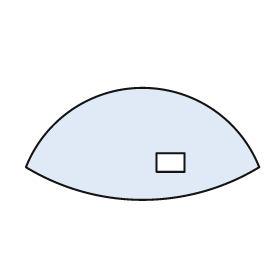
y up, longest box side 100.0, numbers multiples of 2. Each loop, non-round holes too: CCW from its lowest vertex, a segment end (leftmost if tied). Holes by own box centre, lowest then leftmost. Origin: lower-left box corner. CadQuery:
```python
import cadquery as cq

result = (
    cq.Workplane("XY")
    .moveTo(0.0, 14.0)
    .threePointArc((50.0, 0.0), (100.0, 14.0))
    .threePointArc((50.0, 48.0), (0.0, 14.0))
    .close()
    .moveTo(56.0, 12.0)
    .lineTo(68.0, 12.0)
    .lineTo(68.0, 20.0)
    .lineTo(56.0, 20.0)
    .close()
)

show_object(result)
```